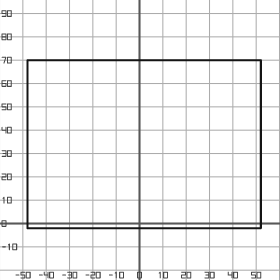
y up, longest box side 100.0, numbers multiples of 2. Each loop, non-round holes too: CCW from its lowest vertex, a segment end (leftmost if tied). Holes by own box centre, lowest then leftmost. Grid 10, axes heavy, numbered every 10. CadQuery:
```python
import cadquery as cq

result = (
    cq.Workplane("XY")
    .moveTo(-48.0, -2.0)
    .lineTo(52.0, -2.0)
    .lineTo(52.0, 70.0)
    .lineTo(-48.0, 70.0)
    .close()
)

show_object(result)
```